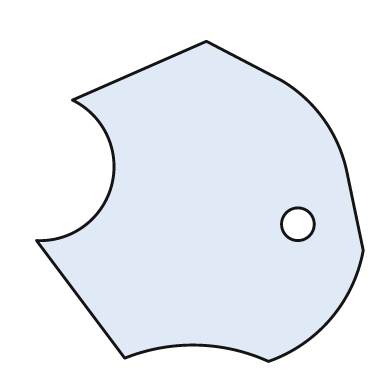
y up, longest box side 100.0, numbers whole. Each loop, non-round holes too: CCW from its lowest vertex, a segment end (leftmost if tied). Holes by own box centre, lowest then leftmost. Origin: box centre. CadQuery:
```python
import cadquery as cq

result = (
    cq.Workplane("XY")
    .moveTo(21.0, -49.0)
    .threePointArc((40.0, -36.0), (50.0, -15.0))
    .lineTo(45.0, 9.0)
    .threePointArc((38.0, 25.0), (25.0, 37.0))
    .lineTo(2.0, 49.0)
    .lineTo(-39.0, 31.0)
    .threePointArc((-27.0, 5.0), (-50.0, -12.0))
    .lineTo(-23.0, -48.0)
    .threePointArc((-1.0, -44.0), (21.0, -49.0))
    .close()
    .moveTo(30.0, -7.0)
    .circle(5.0)
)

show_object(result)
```